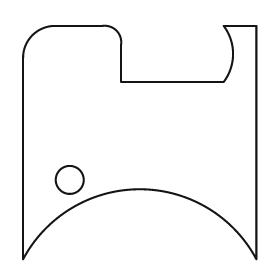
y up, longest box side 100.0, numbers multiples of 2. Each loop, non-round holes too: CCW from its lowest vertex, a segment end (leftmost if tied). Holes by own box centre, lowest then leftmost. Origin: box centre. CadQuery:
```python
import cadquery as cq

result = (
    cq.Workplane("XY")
    .moveTo(-50.0, -50.0)
    .threePointArc((0.0, -20.0), (50.0, -50.0))
    .lineTo(50.0, 50.0)
    .lineTo(36.0, 50.0)
    .threePointArc((40.0, 38.0), (36.0, 26.0))
    .lineTo(-8.0, 26.0)
    .lineTo(-8.0, 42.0)
    .threePointArc((-10.0, 48.0), (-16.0, 50.0))
    .lineTo(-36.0, 50.0)
    .threePointArc((-46.0, 46.0), (-50.0, 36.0))
    .close()
    .moveTo(-30.0, -16.0)
    .circle(6.0)
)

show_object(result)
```